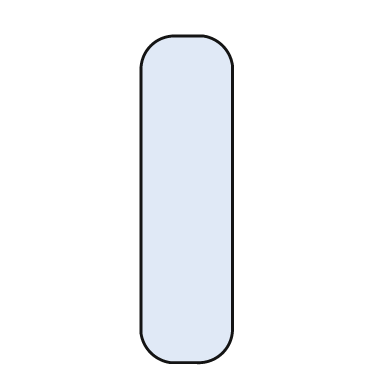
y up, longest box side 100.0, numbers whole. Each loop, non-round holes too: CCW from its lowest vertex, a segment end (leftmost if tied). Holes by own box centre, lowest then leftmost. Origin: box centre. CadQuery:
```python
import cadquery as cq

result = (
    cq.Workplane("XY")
    .moveTo(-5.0, -50.0)
    .lineTo(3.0, -50.0)
    .threePointArc((11.0, -47.0), (14.0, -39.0))
    .lineTo(14.0, 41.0)
    .threePointArc((11.0, 47.0), (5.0, 50.0))
    .lineTo(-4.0, 50.0)
    .threePointArc((-11.0, 47.0), (-14.0, 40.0))
    .lineTo(-14.0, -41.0)
    .threePointArc((-11.0, -47.0), (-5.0, -50.0))
    .close()
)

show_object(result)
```